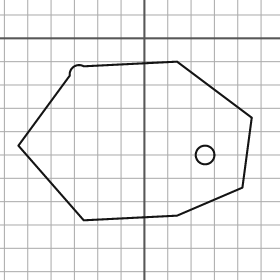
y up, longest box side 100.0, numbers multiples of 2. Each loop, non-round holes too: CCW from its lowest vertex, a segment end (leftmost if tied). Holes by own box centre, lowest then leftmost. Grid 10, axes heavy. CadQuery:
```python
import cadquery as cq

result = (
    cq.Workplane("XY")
    .moveTo(-26.0, -78.0)
    .lineTo(14.0, -76.0)
    .lineTo(42.0, -64.0)
    .lineTo(46.0, -34.0)
    .lineTo(14.0, -10.0)
    .lineTo(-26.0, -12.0)
    .threePointArc((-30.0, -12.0), (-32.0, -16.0))
    .lineTo(-54.0, -46.0)
    .close()
    .moveTo(26.0, -50.0)
    .circle(4.0)
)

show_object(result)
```